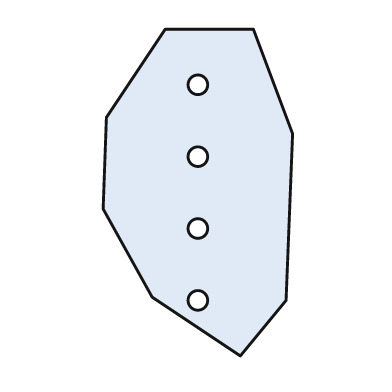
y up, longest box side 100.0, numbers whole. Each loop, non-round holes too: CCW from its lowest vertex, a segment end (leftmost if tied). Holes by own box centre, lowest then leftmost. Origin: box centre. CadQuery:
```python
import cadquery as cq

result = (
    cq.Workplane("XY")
    .moveTo(13.0, -50.0)
    .lineTo(27.0, -33.0)
    .lineTo(29.0, 18.0)
    .lineTo(17.0, 50.0)
    .lineTo(-10.0, 50.0)
    .lineTo(-28.0, 23.0)
    .lineTo(-29.0, -5.0)
    .lineTo(-14.0, -32.0)
    .close()
    .moveTo(0.0, -33.0)
    .circle(3.0)
    .moveTo(0.0, -11.0)
    .circle(3.0)
    .moveTo(0.0, 11.0)
    .circle(3.0)
    .moveTo(0.0, 33.0)
    .circle(3.0)
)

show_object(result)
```